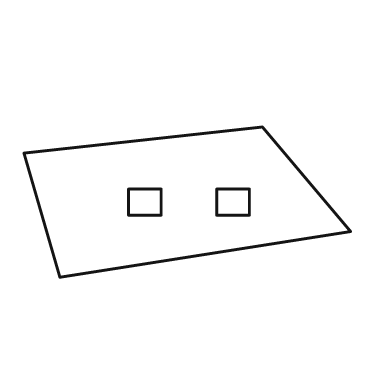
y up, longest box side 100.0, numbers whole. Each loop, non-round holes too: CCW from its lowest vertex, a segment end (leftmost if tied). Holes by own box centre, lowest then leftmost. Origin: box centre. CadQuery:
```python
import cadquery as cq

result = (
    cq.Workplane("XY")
    .moveTo(-39.0, -23.0)
    .lineTo(50.0, -9.0)
    .lineTo(23.0, 23.0)
    .lineTo(-50.0, 15.0)
    .close()
    .moveTo(-18.0, -4.0)
    .lineTo(-8.0, -4.0)
    .lineTo(-8.0, 4.0)
    .lineTo(-18.0, 4.0)
    .close()
    .moveTo(9.0, -4.0)
    .lineTo(19.0, -4.0)
    .lineTo(19.0, 4.0)
    .lineTo(9.0, 4.0)
    .close()
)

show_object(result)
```